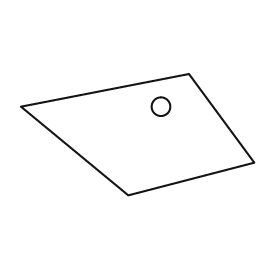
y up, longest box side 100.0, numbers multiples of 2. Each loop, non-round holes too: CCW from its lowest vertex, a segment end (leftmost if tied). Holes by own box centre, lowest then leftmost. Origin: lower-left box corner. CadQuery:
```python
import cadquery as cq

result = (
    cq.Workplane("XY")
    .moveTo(46.0, 0.0)
    .lineTo(100.0, 14.0)
    .lineTo(72.0, 52.0)
    .lineTo(0.0, 38.0)
    .close()
    .moveTo(60.0, 38.0)
    .circle(4.0)
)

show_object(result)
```